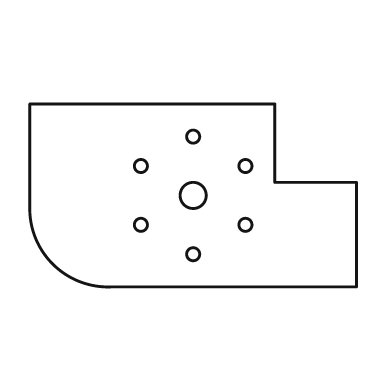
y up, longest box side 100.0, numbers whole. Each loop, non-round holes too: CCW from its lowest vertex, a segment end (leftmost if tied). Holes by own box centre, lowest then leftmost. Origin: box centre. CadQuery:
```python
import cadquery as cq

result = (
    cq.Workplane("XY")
    .moveTo(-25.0, -28.0)
    .lineTo(50.0, -28.0)
    .lineTo(50.0, 4.0)
    .lineTo(25.0, 4.0)
    .lineTo(25.0, 28.0)
    .lineTo(-50.0, 28.0)
    .lineTo(-50.0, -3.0)
    .threePointArc((-43.0, -21.0), (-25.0, -28.0))
    .close()
    .moveTo(0.0, -18.0)
    .circle(2.0)
    .moveTo(-16.0, -9.0)
    .circle(2.0)
    .moveTo(16.0, -9.0)
    .circle(2.0)
    .moveTo(0.0, 0.0)
    .circle(4.0)
    .moveTo(-16.0, 9.0)
    .circle(2.0)
    .moveTo(16.0, 9.0)
    .circle(2.0)
    .moveTo(0.0, 18.0)
    .circle(2.0)
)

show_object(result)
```